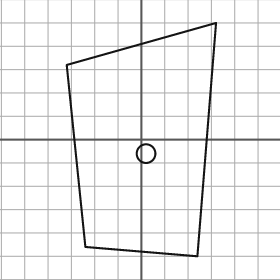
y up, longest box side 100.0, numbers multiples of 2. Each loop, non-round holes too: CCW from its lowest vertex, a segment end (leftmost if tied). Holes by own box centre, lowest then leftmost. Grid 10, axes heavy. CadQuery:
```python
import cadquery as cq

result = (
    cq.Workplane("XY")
    .moveTo(24.0, -50.0)
    .lineTo(32.0, 50.0)
    .lineTo(-32.0, 32.0)
    .lineTo(-24.0, -46.0)
    .close()
    .moveTo(2.0, -6.0)
    .circle(4.0)
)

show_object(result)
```